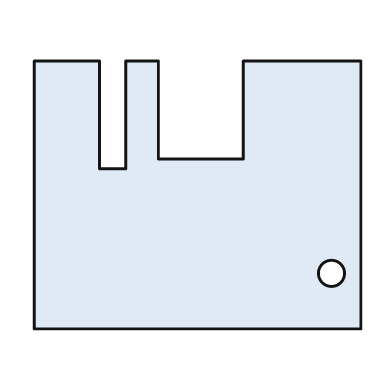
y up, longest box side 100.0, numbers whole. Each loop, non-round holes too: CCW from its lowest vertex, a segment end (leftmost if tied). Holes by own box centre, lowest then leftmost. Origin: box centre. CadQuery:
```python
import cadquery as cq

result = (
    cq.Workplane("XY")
    .moveTo(-50.0, -41.0)
    .lineTo(50.0, -41.0)
    .lineTo(50.0, 41.0)
    .lineTo(14.0, 41.0)
    .lineTo(14.0, 11.0)
    .lineTo(-12.0, 11.0)
    .lineTo(-12.0, 41.0)
    .lineTo(-22.0, 41.0)
    .lineTo(-22.0, 8.0)
    .lineTo(-30.0, 8.0)
    .lineTo(-30.0, 41.0)
    .lineTo(-50.0, 41.0)
    .close()
    .moveTo(41.0, -24.0)
    .circle(4.0)
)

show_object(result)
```